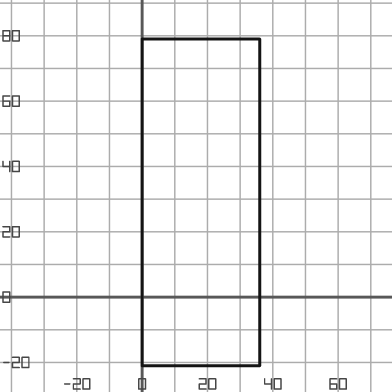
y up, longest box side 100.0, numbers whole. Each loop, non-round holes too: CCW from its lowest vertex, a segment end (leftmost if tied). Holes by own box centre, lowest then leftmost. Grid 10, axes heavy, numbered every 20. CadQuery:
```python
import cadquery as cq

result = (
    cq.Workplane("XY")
    .moveTo(0.0, -21.0)
    .lineTo(36.0, -21.0)
    .lineTo(36.0, 79.0)
    .lineTo(0.0, 79.0)
    .close()
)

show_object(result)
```